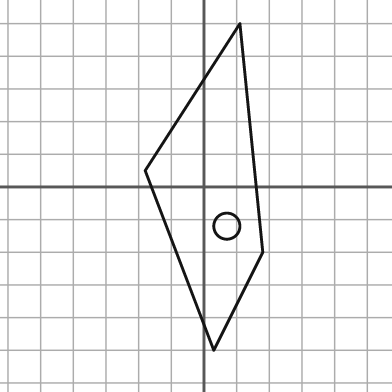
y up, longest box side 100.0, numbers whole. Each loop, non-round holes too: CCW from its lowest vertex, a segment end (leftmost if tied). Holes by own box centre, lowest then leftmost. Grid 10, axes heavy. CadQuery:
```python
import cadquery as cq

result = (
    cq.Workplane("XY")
    .moveTo(3.0, -50.0)
    .lineTo(18.0, -20.0)
    .lineTo(11.0, 50.0)
    .lineTo(-18.0, 5.0)
    .close()
    .moveTo(7.0, -12.0)
    .circle(4.0)
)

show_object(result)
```